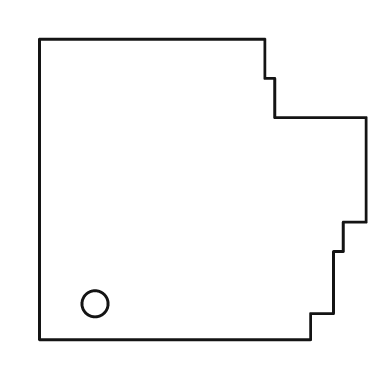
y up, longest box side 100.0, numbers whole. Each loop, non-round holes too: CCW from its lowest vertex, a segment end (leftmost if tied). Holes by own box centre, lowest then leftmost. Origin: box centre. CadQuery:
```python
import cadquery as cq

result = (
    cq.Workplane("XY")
    .moveTo(-50.0, -46.0)
    .lineTo(33.0, -46.0)
    .lineTo(33.0, -38.0)
    .lineTo(40.0, -38.0)
    .lineTo(40.0, -19.0)
    .lineTo(43.0, -19.0)
    .lineTo(43.0, -10.0)
    .lineTo(50.0, -10.0)
    .lineTo(50.0, 22.0)
    .lineTo(22.0, 22.0)
    .lineTo(22.0, 34.0)
    .lineTo(19.0, 34.0)
    .lineTo(19.0, 46.0)
    .lineTo(-50.0, 46.0)
    .close()
    .moveTo(-33.0, -35.0)
    .circle(4.0)
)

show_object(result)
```